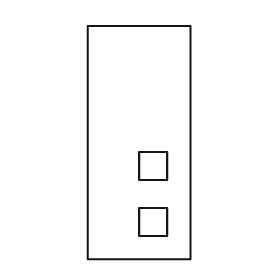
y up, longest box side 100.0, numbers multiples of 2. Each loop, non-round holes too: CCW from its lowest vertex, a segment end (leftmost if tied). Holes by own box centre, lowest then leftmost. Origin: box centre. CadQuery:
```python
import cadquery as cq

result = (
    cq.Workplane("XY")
    .moveTo(-22.0, -50.0)
    .lineTo(22.0, -50.0)
    .lineTo(22.0, 50.0)
    .lineTo(-22.0, 50.0)
    .close()
    .moveTo(0.0, -40.0)
    .lineTo(12.0, -40.0)
    .lineTo(12.0, -28.0)
    .lineTo(0.0, -28.0)
    .close()
    .moveTo(0.0, -16.0)
    .lineTo(12.0, -16.0)
    .lineTo(12.0, -4.0)
    .lineTo(0.0, -4.0)
    .close()
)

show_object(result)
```